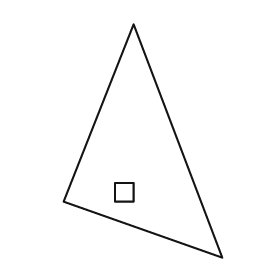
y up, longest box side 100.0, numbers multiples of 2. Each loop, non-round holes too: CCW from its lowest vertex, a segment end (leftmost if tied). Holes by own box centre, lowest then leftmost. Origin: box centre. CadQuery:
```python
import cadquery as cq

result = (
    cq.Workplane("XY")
    .moveTo(34.0, -50.0)
    .lineTo(-4.0, 50.0)
    .lineTo(-34.0, -26.0)
    .close()
    .moveTo(-12.0, -26.0)
    .lineTo(-4.0, -26.0)
    .lineTo(-4.0, -18.0)
    .lineTo(-12.0, -18.0)
    .close()
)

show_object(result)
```